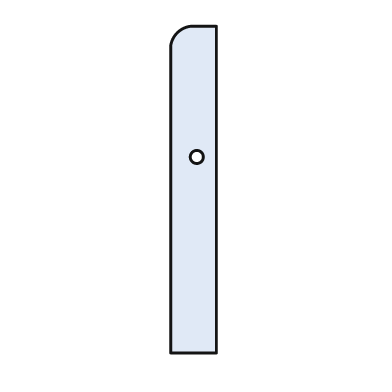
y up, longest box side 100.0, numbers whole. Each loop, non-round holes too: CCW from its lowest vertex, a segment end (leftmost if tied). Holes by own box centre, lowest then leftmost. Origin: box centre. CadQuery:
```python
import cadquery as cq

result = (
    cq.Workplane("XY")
    .moveTo(-7.0, -50.0)
    .lineTo(7.0, -50.0)
    .lineTo(7.0, 50.0)
    .lineTo(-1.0, 50.0)
    .threePointArc((-5.0, 48.0), (-7.0, 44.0))
    .close()
    .moveTo(1.0, 10.0)
    .circle(2.0)
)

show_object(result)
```